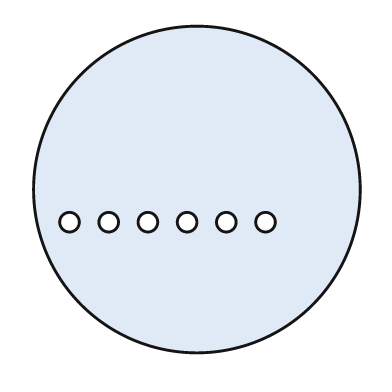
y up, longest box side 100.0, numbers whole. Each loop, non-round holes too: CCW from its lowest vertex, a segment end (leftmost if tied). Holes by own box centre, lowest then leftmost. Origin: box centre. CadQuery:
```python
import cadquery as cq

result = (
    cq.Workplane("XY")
    .moveTo(0.0, 0.0)
    .circle(50.0)
    .moveTo(-39.0, -10.0)
    .circle(3.0)
    .moveTo(-27.0, -10.0)
    .circle(3.0)
    .moveTo(-15.0, -10.0)
    .circle(3.0)
    .moveTo(-3.0, -10.0)
    .circle(3.0)
    .moveTo(9.0, -10.0)
    .circle(3.0)
    .moveTo(21.0, -10.0)
    .circle(3.0)
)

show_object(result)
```